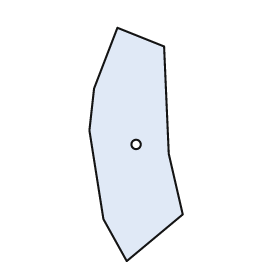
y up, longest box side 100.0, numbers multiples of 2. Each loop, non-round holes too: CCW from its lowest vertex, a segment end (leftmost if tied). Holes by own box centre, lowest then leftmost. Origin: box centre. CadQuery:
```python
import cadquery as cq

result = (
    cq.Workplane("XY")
    .moveTo(-4.0, -50.0)
    .lineTo(20.0, -30.0)
    .lineTo(14.0, -4.0)
    .lineTo(12.0, 42.0)
    .lineTo(-8.0, 50.0)
    .lineTo(-18.0, 24.0)
    .lineTo(-20.0, 6.0)
    .lineTo(-14.0, -32.0)
    .close()
    .moveTo(0.0, 0.0)
    .circle(2.0)
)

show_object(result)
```